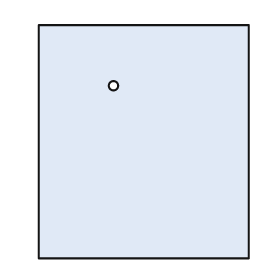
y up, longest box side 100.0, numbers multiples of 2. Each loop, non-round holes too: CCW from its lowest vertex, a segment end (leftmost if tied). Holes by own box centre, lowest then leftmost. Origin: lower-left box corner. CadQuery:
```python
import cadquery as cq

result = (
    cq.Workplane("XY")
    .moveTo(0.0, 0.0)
    .lineTo(90.0, 0.0)
    .lineTo(90.0, 100.0)
    .lineTo(0.0, 100.0)
    .close()
    .moveTo(32.0, 74.0)
    .circle(2.0)
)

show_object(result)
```